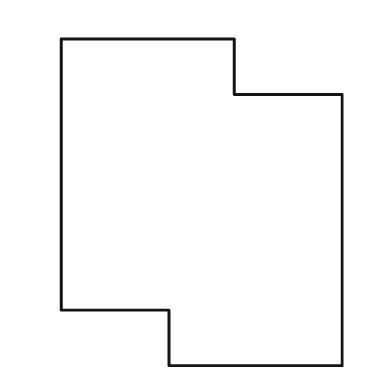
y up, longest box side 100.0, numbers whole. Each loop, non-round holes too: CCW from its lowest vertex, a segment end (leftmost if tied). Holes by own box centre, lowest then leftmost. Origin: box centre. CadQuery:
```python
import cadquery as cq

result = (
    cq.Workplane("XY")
    .moveTo(-10.0, -50.0)
    .lineTo(43.0, -50.0)
    .lineTo(43.0, 33.0)
    .lineTo(10.0, 33.0)
    .lineTo(10.0, 50.0)
    .lineTo(-43.0, 50.0)
    .lineTo(-43.0, -33.0)
    .lineTo(-10.0, -33.0)
    .close()
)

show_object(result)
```